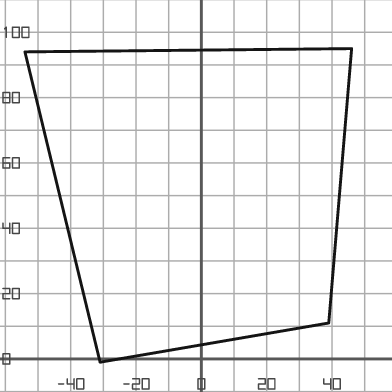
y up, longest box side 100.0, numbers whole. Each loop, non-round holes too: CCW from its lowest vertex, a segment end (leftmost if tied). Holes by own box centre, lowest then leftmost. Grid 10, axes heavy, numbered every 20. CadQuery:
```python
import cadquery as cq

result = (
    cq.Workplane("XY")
    .moveTo(-31.0, -1.0)
    .lineTo(39.0, 11.0)
    .lineTo(46.0, 95.0)
    .lineTo(-54.0, 94.0)
    .close()
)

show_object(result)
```